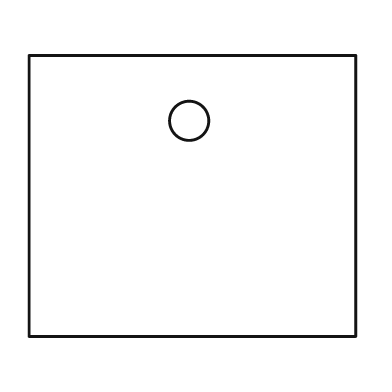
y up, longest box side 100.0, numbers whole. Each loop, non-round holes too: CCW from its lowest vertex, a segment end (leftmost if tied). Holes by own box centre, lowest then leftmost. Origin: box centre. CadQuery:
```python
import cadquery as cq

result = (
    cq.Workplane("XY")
    .moveTo(-50.0, -43.0)
    .lineTo(50.0, -43.0)
    .lineTo(50.0, 43.0)
    .lineTo(-50.0, 43.0)
    .close()
    .moveTo(-1.0, 23.0)
    .circle(6.0)
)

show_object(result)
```